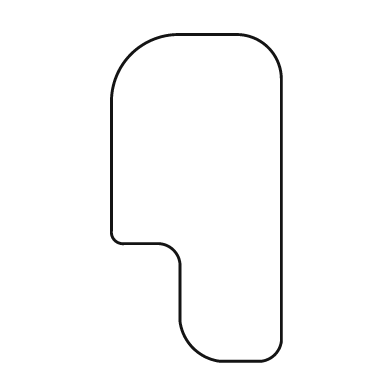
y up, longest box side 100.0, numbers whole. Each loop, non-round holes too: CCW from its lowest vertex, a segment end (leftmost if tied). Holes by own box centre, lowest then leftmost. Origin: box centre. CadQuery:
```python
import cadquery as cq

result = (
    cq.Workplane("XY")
    .moveTo(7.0, -50.0)
    .lineTo(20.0, -50.0)
    .threePointArc((24.0, -48.0), (26.0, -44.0))
    .lineTo(26.0, 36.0)
    .threePointArc((22.0, 46.0), (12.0, 50.0))
    .lineTo(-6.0, 50.0)
    .threePointArc((-20.0, 44.0), (-26.0, 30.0))
    .lineTo(-26.0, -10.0)
    .threePointArc((-25.0, -13.0), (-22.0, -14.0))
    .lineTo(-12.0, -14.0)
    .threePointArc((-7.0, -16.0), (-5.0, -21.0))
    .lineTo(-5.0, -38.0)
    .threePointArc((-1.0, -46.0), (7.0, -50.0))
    .close()
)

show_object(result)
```